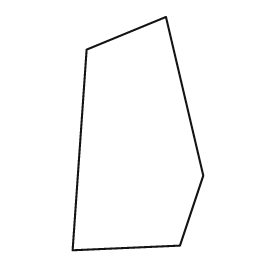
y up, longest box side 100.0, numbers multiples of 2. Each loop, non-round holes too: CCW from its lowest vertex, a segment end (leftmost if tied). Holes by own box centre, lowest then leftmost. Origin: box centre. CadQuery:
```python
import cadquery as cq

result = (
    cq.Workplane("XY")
    .moveTo(-28.0, -50.0)
    .lineTo(18.0, -48.0)
    .lineTo(28.0, -18.0)
    .lineTo(12.0, 50.0)
    .lineTo(-22.0, 36.0)
    .close()
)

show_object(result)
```